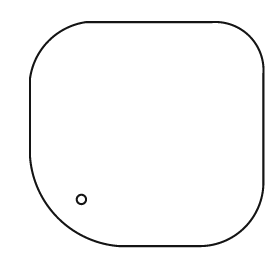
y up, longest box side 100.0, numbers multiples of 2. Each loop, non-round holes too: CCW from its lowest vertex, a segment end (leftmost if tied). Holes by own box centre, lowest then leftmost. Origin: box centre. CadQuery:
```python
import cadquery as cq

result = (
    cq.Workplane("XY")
    .moveTo(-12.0, -48.0)
    .lineTo(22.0, -48.0)
    .threePointArc((42.0, -40.0), (50.0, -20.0))
    .lineTo(50.0, 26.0)
    .threePointArc((44.0, 42.0), (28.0, 48.0))
    .lineTo(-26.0, 48.0)
    .threePointArc((-42.0, 40.0), (-50.0, 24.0))
    .lineTo(-50.0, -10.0)
    .threePointArc((-38.0, -36.0), (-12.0, -48.0))
    .close()
    .moveTo(-28.0, -28.0)
    .circle(2.0)
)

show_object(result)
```